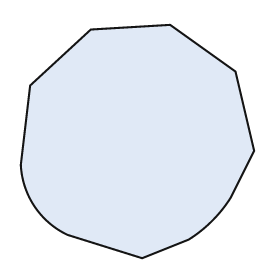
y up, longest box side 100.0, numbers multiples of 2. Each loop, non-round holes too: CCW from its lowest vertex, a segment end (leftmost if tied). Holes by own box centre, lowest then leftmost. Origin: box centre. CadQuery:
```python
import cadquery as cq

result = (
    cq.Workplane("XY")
    .moveTo(2.0, -50.0)
    .lineTo(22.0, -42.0)
    .threePointArc((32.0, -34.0), (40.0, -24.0))
    .lineTo(50.0, -4.0)
    .lineTo(42.0, 30.0)
    .lineTo(14.0, 50.0)
    .lineTo(-20.0, 48.0)
    .lineTo(-46.0, 24.0)
    .lineTo(-50.0, -10.0)
    .threePointArc((-44.0, -28.0), (-30.0, -40.0))
    .close()
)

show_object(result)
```